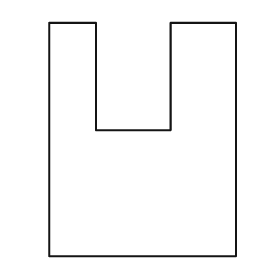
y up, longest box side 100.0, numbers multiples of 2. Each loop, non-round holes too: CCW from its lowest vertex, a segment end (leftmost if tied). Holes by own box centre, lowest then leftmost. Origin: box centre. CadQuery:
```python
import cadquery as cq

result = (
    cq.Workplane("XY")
    .moveTo(-40.0, -50.0)
    .lineTo(40.0, -50.0)
    .lineTo(40.0, 50.0)
    .lineTo(12.0, 50.0)
    .lineTo(12.0, 4.0)
    .lineTo(-20.0, 4.0)
    .lineTo(-20.0, 50.0)
    .lineTo(-40.0, 50.0)
    .close()
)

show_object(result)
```